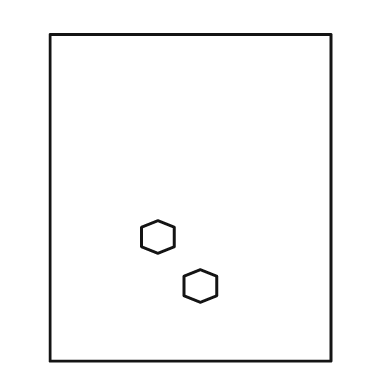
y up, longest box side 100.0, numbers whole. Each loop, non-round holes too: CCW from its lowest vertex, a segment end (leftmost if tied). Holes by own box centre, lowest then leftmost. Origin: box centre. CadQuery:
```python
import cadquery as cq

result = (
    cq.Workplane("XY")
    .moveTo(-43.0, -50.0)
    .lineTo(43.0, -50.0)
    .lineTo(43.0, 50.0)
    .lineTo(-43.0, 50.0)
    .close()
    .moveTo(3.0, -32.0)
    .lineTo(8.0, -30.0)
    .lineTo(8.0, -24.0)
    .lineTo(3.0, -22.0)
    .lineTo(-2.0, -24.0)
    .lineTo(-2.0, -30.0)
    .close()
    .moveTo(-10.0, -17.0)
    .lineTo(-5.0, -15.0)
    .lineTo(-5.0, -9.0)
    .lineTo(-10.0, -7.0)
    .lineTo(-15.0, -9.0)
    .lineTo(-15.0, -15.0)
    .close()
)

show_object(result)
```